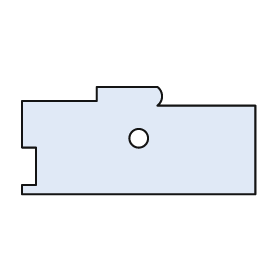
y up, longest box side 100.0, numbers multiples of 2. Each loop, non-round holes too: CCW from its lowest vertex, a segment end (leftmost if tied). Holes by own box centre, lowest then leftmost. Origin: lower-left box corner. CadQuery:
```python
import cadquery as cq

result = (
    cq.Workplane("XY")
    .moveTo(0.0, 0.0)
    .lineTo(100.0, 0.0)
    .lineTo(100.0, 38.0)
    .lineTo(58.0, 38.0)
    .threePointArc((60.0, 42.0), (58.0, 46.0))
    .lineTo(32.0, 46.0)
    .lineTo(32.0, 40.0)
    .lineTo(0.0, 40.0)
    .lineTo(0.0, 20.0)
    .lineTo(6.0, 20.0)
    .lineTo(6.0, 4.0)
    .lineTo(0.0, 4.0)
    .close()
    .moveTo(50.0, 24.0)
    .circle(4.0)
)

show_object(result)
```